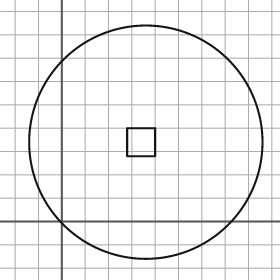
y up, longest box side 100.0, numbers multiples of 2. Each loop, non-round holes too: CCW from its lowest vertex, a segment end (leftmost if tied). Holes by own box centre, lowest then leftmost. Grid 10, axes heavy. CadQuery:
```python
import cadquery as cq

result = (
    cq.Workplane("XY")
    .moveTo(36.0, 34.0)
    .circle(50.0)
    .moveTo(28.0, 28.0)
    .lineTo(40.0, 28.0)
    .lineTo(40.0, 40.0)
    .lineTo(28.0, 40.0)
    .close()
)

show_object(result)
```